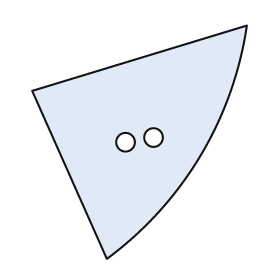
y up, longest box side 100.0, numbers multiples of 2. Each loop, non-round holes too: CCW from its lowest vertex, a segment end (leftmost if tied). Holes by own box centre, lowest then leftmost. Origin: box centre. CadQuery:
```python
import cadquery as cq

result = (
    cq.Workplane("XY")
    .moveTo(-14.0, -50.0)
    .threePointArc((26.0, -6.0), (46.0, 50.0))
    .lineTo(-46.0, 22.0)
    .close()
    .moveTo(-6.0, 0.0)
    .circle(4.0)
    .moveTo(6.0, 2.0)
    .circle(4.0)
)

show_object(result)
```